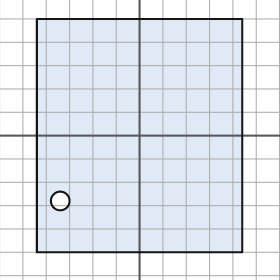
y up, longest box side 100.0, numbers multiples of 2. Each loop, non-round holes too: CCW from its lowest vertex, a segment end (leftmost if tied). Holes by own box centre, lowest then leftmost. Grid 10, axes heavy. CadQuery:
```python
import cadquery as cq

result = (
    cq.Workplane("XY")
    .moveTo(-44.0, -50.0)
    .lineTo(44.0, -50.0)
    .lineTo(44.0, 50.0)
    .lineTo(-44.0, 50.0)
    .close()
    .moveTo(-34.0, -28.0)
    .circle(4.0)
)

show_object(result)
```